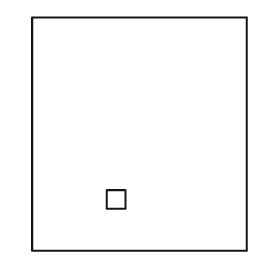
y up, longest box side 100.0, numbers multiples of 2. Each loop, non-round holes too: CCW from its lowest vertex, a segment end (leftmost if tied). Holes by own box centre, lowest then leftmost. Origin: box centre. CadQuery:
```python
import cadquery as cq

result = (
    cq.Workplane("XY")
    .moveTo(-46.0, -50.0)
    .lineTo(46.0, -50.0)
    .lineTo(46.0, 50.0)
    .lineTo(-46.0, 50.0)
    .close()
    .moveTo(-14.0, -32.0)
    .lineTo(-6.0, -32.0)
    .lineTo(-6.0, -24.0)
    .lineTo(-14.0, -24.0)
    .close()
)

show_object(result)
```